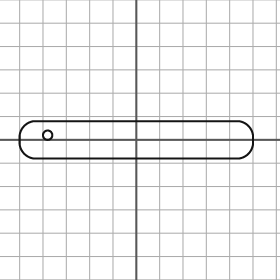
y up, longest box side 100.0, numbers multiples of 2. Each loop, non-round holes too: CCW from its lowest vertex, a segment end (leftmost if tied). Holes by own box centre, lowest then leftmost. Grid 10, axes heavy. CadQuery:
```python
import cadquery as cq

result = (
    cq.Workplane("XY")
    .moveTo(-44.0, -8.0)
    .lineTo(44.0, -8.0)
    .threePointArc((48.0, -6.0), (50.0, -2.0))
    .lineTo(50.0, 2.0)
    .threePointArc((48.0, 6.0), (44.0, 8.0))
    .lineTo(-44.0, 8.0)
    .threePointArc((-48.0, 6.0), (-50.0, 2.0))
    .lineTo(-50.0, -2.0)
    .threePointArc((-48.0, -6.0), (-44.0, -8.0))
    .close()
    .moveTo(-38.0, 2.0)
    .circle(2.0)
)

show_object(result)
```